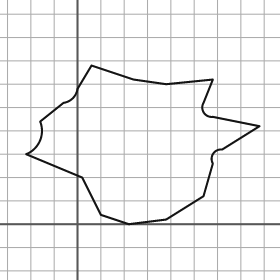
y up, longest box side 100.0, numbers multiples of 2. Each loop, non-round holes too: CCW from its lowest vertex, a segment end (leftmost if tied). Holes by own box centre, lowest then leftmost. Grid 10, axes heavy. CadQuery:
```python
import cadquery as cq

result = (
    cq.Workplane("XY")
    .moveTo(22.0, 0.0)
    .lineTo(38.0, 2.0)
    .lineTo(54.0, 12.0)
    .lineTo(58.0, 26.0)
    .threePointArc((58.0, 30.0), (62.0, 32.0))
    .lineTo(78.0, 42.0)
    .lineTo(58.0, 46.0)
    .threePointArc((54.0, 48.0), (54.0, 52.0))
    .lineTo(58.0, 62.0)
    .lineTo(38.0, 60.0)
    .lineTo(24.0, 62.0)
    .lineTo(6.0, 68.0)
    .lineTo(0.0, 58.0)
    .threePointArc((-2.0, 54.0), (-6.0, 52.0))
    .lineTo(-16.0, 44.0)
    .threePointArc((-16.0, 36.0), (-22.0, 30.0))
    .lineTo(2.0, 20.0)
    .lineTo(10.0, 4.0)
    .close()
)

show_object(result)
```